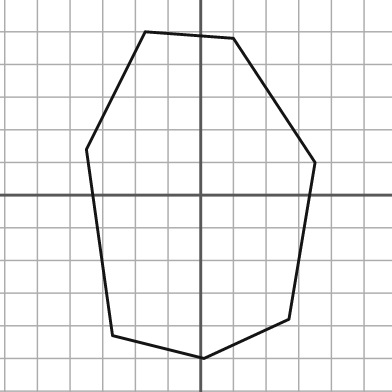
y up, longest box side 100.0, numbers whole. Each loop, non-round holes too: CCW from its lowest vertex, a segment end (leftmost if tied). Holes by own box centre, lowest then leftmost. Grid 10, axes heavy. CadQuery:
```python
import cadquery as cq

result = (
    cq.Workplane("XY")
    .moveTo(1.0, -50.0)
    .lineTo(27.0, -38.0)
    .lineTo(35.0, 10.0)
    .lineTo(10.0, 48.0)
    .lineTo(-17.0, 50.0)
    .lineTo(-35.0, 14.0)
    .lineTo(-27.0, -43.0)
    .close()
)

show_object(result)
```